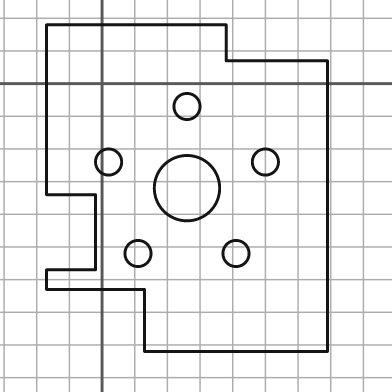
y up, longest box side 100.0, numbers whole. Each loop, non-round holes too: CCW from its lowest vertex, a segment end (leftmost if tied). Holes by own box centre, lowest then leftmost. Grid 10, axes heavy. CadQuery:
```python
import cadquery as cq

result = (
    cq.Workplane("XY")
    .moveTo(13.0, -82.0)
    .lineTo(69.0, -82.0)
    .lineTo(69.0, 7.0)
    .lineTo(38.0, 7.0)
    .lineTo(38.0, 18.0)
    .lineTo(-17.0, 18.0)
    .lineTo(-17.0, -34.0)
    .lineTo(-2.0, -34.0)
    .lineTo(-2.0, -57.0)
    .lineTo(-17.0, -57.0)
    .lineTo(-17.0, -63.0)
    .lineTo(13.0, -63.0)
    .close()
    .moveTo(11.0, -52.0)
    .circle(4.0)
    .moveTo(41.0, -52.0)
    .circle(4.0)
    .moveTo(26.0, -32.0)
    .circle(10.0)
    .moveTo(2.0, -24.0)
    .circle(4.0)
    .moveTo(50.0, -24.0)
    .circle(4.0)
    .moveTo(26.0, -7.0)
    .circle(4.0)
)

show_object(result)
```